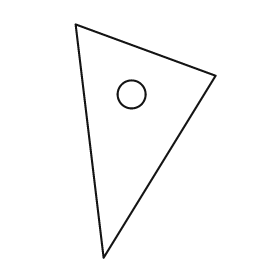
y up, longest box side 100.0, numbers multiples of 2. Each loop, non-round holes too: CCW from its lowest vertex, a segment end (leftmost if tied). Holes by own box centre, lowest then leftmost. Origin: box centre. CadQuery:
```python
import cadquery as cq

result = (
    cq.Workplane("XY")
    .moveTo(-18.0, -50.0)
    .lineTo(30.0, 28.0)
    .lineTo(-30.0, 50.0)
    .close()
    .moveTo(-6.0, 20.0)
    .circle(6.0)
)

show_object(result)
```